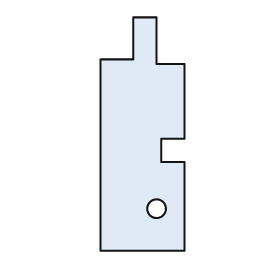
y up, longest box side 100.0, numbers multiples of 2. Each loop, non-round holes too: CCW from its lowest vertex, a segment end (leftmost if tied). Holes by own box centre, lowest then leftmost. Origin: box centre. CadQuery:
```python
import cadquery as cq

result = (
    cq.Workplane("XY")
    .moveTo(-18.0, -50.0)
    .lineTo(18.0, -50.0)
    .lineTo(18.0, -12.0)
    .lineTo(8.0, -12.0)
    .lineTo(8.0, -2.0)
    .lineTo(18.0, -2.0)
    .lineTo(18.0, 30.0)
    .lineTo(6.0, 30.0)
    .lineTo(6.0, 50.0)
    .lineTo(-4.0, 50.0)
    .lineTo(-4.0, 32.0)
    .lineTo(-18.0, 32.0)
    .close()
    .moveTo(6.0, -32.0)
    .circle(4.0)
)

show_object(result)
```